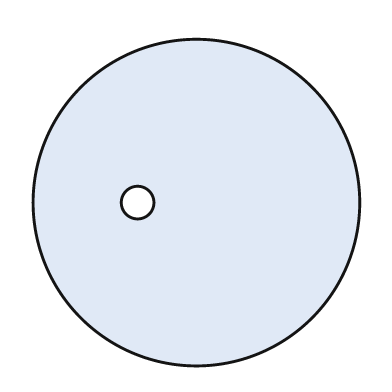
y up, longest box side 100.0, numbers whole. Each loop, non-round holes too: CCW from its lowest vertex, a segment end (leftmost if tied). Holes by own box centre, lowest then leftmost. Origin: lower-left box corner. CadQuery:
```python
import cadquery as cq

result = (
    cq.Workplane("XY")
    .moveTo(50.0, 50.0)
    .circle(50.0)
    .moveTo(32.0, 50.0)
    .circle(5.0)
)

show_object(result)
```